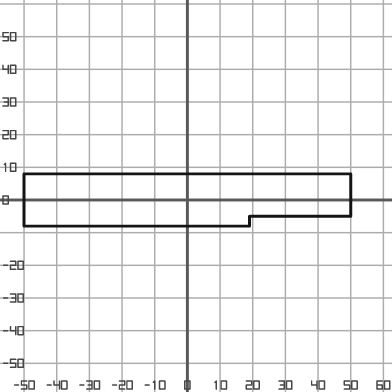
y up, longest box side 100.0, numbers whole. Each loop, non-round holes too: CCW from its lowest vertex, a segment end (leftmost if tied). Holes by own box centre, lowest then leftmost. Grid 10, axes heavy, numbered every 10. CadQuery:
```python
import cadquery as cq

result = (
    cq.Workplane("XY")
    .moveTo(-50.0, -8.0)
    .lineTo(19.0, -8.0)
    .lineTo(19.0, -5.0)
    .lineTo(50.0, -5.0)
    .lineTo(50.0, 8.0)
    .lineTo(-50.0, 8.0)
    .close()
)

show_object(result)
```